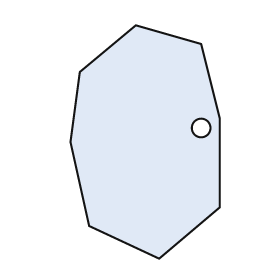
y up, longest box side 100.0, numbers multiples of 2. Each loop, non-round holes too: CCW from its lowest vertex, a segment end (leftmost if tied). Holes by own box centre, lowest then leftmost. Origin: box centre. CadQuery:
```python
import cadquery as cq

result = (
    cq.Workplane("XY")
    .moveTo(6.0, -50.0)
    .lineTo(32.0, -28.0)
    .lineTo(32.0, 10.0)
    .lineTo(24.0, 42.0)
    .lineTo(-4.0, 50.0)
    .lineTo(-28.0, 30.0)
    .lineTo(-32.0, 0.0)
    .lineTo(-24.0, -36.0)
    .close()
    .moveTo(24.0, 6.0)
    .circle(4.0)
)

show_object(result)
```